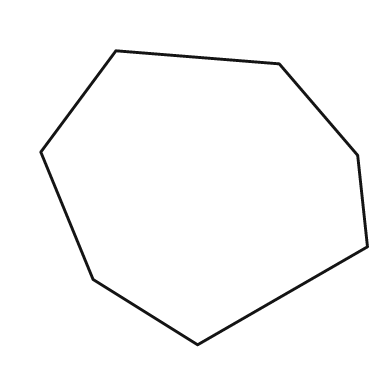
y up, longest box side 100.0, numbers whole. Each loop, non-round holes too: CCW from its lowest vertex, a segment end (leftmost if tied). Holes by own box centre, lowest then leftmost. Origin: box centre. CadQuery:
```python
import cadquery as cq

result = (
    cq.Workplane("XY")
    .moveTo(-2.0, -45.0)
    .lineTo(50.0, -15.0)
    .lineTo(47.0, 13.0)
    .lineTo(23.0, 41.0)
    .lineTo(-27.0, 45.0)
    .lineTo(-50.0, 14.0)
    .lineTo(-34.0, -25.0)
    .close()
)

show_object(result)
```